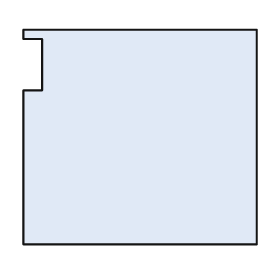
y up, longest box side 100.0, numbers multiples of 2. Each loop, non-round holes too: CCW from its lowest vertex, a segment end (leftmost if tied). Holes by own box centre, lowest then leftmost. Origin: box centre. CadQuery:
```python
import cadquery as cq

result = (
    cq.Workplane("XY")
    .moveTo(-50.0, -46.0)
    .lineTo(50.0, -46.0)
    .lineTo(50.0, 46.0)
    .lineTo(-50.0, 46.0)
    .lineTo(-50.0, 42.0)
    .lineTo(-42.0, 42.0)
    .lineTo(-42.0, 20.0)
    .lineTo(-50.0, 20.0)
    .close()
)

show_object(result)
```